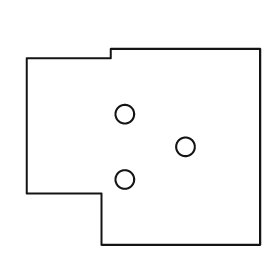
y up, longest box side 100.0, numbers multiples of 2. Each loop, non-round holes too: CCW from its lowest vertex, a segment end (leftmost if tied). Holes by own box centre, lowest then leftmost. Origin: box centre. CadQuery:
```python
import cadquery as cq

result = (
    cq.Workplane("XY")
    .moveTo(-18.0, -42.0)
    .lineTo(50.0, -42.0)
    .lineTo(50.0, 42.0)
    .lineTo(-14.0, 42.0)
    .lineTo(-14.0, 38.0)
    .lineTo(-50.0, 38.0)
    .lineTo(-50.0, -20.0)
    .lineTo(-18.0, -20.0)
    .close()
    .moveTo(-8.0, -14.0)
    .circle(4.0)
    .moveTo(18.0, 0.0)
    .circle(4.0)
    .moveTo(-8.0, 14.0)
    .circle(4.0)
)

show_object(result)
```